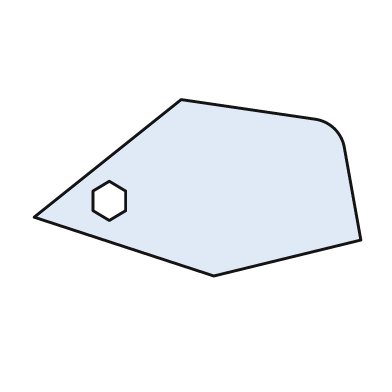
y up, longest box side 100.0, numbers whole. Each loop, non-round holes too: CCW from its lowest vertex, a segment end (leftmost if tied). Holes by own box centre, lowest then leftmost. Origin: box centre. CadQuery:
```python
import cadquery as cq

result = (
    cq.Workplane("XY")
    .moveTo(5.0, -27.0)
    .lineTo(50.0, -16.0)
    .lineTo(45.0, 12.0)
    .threePointArc((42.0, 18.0), (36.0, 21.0))
    .lineTo(-5.0, 27.0)
    .lineTo(-50.0, -9.0)
    .close()
    .moveTo(-27.0, -10.0)
    .lineTo(-22.0, -7.0)
    .lineTo(-22.0, -1.0)
    .lineTo(-27.0, 2.0)
    .lineTo(-32.0, -1.0)
    .lineTo(-32.0, -7.0)
    .close()
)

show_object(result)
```